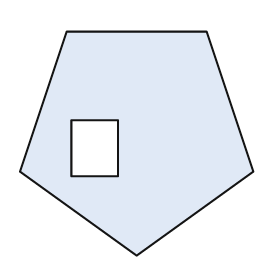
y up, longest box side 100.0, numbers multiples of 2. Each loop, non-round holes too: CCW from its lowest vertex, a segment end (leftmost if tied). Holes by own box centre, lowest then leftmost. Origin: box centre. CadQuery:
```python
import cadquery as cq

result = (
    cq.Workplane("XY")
    .moveTo(0.0, -48.0)
    .lineTo(50.0, -12.0)
    .lineTo(30.0, 48.0)
    .lineTo(-30.0, 48.0)
    .lineTo(-50.0, -12.0)
    .close()
    .moveTo(-28.0, -14.0)
    .lineTo(-8.0, -14.0)
    .lineTo(-8.0, 10.0)
    .lineTo(-28.0, 10.0)
    .close()
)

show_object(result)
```